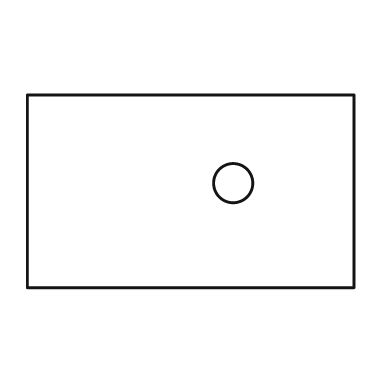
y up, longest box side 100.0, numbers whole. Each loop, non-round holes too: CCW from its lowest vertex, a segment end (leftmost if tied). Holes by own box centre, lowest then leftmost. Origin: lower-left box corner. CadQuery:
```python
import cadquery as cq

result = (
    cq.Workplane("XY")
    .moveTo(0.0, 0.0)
    .lineTo(100.0, 0.0)
    .lineTo(100.0, 59.0)
    .lineTo(0.0, 59.0)
    .close()
    .moveTo(63.0, 32.0)
    .circle(6.0)
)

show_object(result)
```